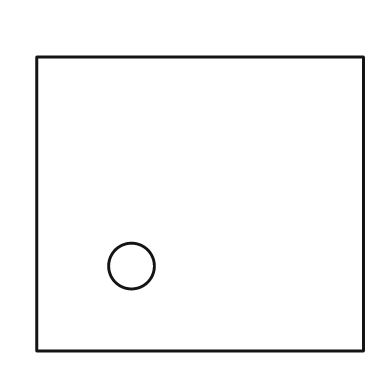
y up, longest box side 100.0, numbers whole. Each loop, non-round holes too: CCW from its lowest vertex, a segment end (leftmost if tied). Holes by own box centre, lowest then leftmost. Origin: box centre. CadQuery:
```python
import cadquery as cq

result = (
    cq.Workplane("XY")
    .moveTo(-50.0, -45.0)
    .lineTo(50.0, -45.0)
    .lineTo(50.0, 45.0)
    .lineTo(-50.0, 45.0)
    .close()
    .moveTo(-21.0, -19.0)
    .circle(7.0)
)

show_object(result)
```